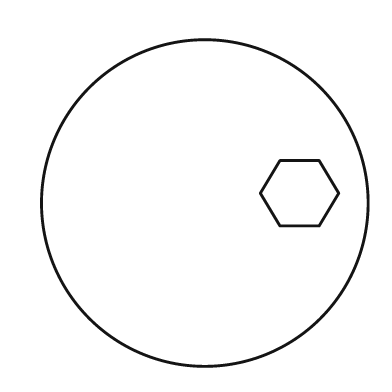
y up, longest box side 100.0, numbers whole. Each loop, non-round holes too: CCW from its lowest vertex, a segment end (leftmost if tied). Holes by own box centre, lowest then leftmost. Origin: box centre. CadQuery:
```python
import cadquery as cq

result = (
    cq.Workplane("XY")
    .moveTo(0.0, 0.0)
    .circle(50.0)
    .moveTo(23.0, -7.0)
    .lineTo(35.0, -7.0)
    .lineTo(41.0, 3.0)
    .lineTo(35.0, 13.0)
    .lineTo(23.0, 13.0)
    .lineTo(17.0, 3.0)
    .close()
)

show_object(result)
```